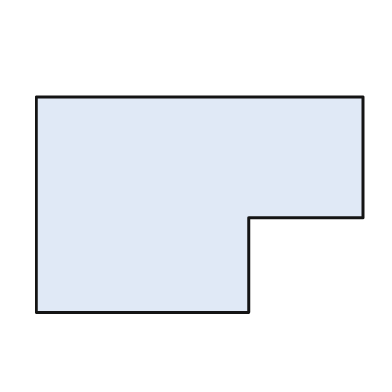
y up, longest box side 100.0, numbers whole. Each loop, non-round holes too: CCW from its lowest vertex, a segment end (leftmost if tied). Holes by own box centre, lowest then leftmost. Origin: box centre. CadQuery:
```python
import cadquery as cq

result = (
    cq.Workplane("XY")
    .moveTo(-50.0, -33.0)
    .lineTo(15.0, -33.0)
    .lineTo(15.0, -4.0)
    .lineTo(50.0, -4.0)
    .lineTo(50.0, 33.0)
    .lineTo(-50.0, 33.0)
    .close()
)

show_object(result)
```